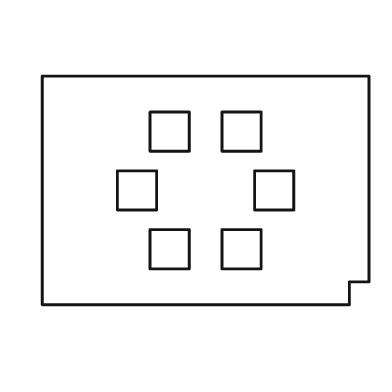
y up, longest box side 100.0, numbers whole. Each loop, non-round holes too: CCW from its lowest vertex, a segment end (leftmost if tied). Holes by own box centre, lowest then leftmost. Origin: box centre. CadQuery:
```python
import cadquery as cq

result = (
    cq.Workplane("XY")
    .moveTo(-50.0, -35.0)
    .lineTo(44.0, -35.0)
    .lineTo(44.0, -28.0)
    .lineTo(50.0, -28.0)
    .lineTo(50.0, 35.0)
    .lineTo(-50.0, 35.0)
    .close()
    .moveTo(-17.0, -24.0)
    .lineTo(-5.0, -24.0)
    .lineTo(-5.0, -12.0)
    .lineTo(-17.0, -12.0)
    .close()
    .moveTo(5.0, -24.0)
    .lineTo(17.0, -24.0)
    .lineTo(17.0, -12.0)
    .lineTo(5.0, -12.0)
    .close()
    .moveTo(-27.0, -6.0)
    .lineTo(-15.0, -6.0)
    .lineTo(-15.0, 6.0)
    .lineTo(-27.0, 6.0)
    .close()
    .moveTo(15.0, -6.0)
    .lineTo(27.0, -6.0)
    .lineTo(27.0, 6.0)
    .lineTo(15.0, 6.0)
    .close()
    .moveTo(-17.0, 12.0)
    .lineTo(-5.0, 12.0)
    .lineTo(-5.0, 24.0)
    .lineTo(-17.0, 24.0)
    .close()
    .moveTo(5.0, 12.0)
    .lineTo(17.0, 12.0)
    .lineTo(17.0, 24.0)
    .lineTo(5.0, 24.0)
    .close()
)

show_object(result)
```